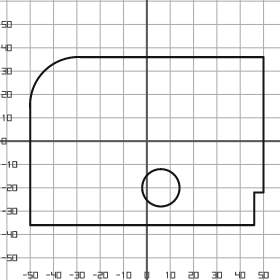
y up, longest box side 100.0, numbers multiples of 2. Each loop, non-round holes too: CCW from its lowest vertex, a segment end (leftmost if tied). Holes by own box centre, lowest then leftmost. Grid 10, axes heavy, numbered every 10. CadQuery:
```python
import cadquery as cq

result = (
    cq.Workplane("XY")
    .moveTo(-50.0, -36.0)
    .lineTo(46.0, -36.0)
    .lineTo(46.0, -22.0)
    .lineTo(50.0, -22.0)
    .lineTo(50.0, 36.0)
    .lineTo(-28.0, 36.0)
    .threePointArc((-44.0, 30.0), (-50.0, 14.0))
    .close()
    .moveTo(6.0, -20.0)
    .circle(8.0)
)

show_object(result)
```